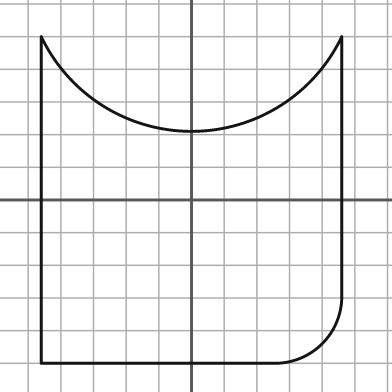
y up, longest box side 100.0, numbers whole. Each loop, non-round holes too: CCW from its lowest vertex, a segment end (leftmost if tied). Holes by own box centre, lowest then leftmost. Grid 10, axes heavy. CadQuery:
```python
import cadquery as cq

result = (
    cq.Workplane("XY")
    .moveTo(-46.0, -50.0)
    .lineTo(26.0, -50.0)
    .threePointArc((40.0, -44.0), (46.0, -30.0))
    .lineTo(46.0, 50.0)
    .threePointArc((0.0, 21.0), (-46.0, 50.0))
    .close()
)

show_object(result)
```